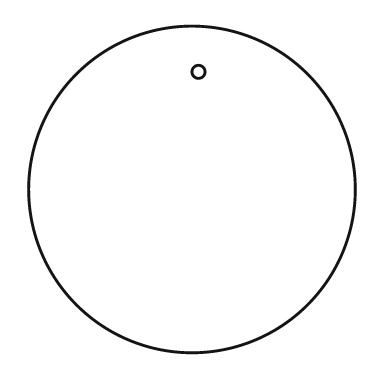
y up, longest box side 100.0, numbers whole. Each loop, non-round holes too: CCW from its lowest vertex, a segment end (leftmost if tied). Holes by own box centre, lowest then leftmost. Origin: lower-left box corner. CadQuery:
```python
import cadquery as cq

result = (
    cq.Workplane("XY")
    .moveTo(50.0, 50.0)
    .circle(50.0)
    .moveTo(52.0, 86.0)
    .circle(2.0)
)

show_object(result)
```